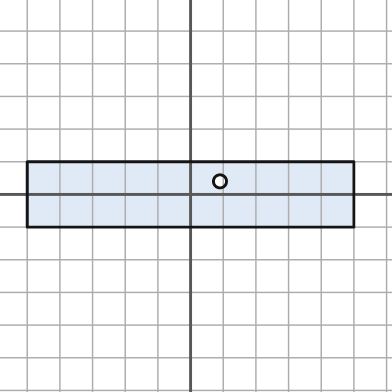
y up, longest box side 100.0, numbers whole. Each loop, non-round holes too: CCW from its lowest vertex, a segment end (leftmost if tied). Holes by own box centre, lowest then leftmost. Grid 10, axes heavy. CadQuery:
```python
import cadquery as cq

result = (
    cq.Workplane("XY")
    .moveTo(-50.0, -10.0)
    .lineTo(50.0, -10.0)
    .lineTo(50.0, 10.0)
    .lineTo(-50.0, 10.0)
    .close()
    .moveTo(9.0, 4.0)
    .circle(2.0)
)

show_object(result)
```